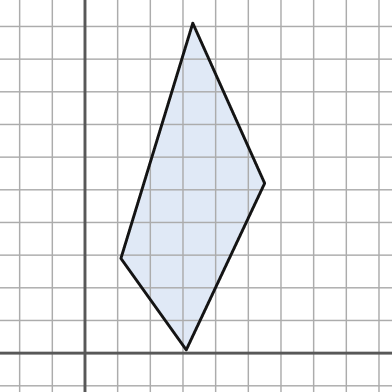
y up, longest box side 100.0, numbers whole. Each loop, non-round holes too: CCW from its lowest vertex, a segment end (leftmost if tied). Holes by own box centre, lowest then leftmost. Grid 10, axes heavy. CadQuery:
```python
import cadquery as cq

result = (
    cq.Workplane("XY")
    .moveTo(31.0, 1.0)
    .lineTo(55.0, 52.0)
    .lineTo(33.0, 101.0)
    .lineTo(11.0, 29.0)
    .close()
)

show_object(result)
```